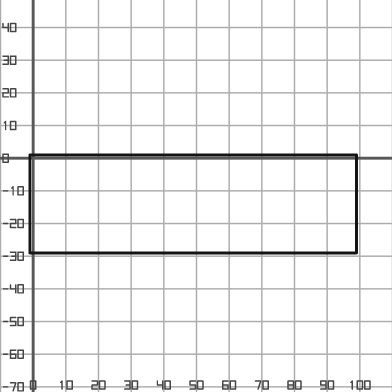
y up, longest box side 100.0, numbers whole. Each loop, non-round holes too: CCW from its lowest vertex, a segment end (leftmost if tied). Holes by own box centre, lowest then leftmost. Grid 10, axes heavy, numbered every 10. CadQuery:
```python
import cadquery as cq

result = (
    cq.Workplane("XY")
    .moveTo(-1.0, -29.0)
    .lineTo(99.0, -29.0)
    .lineTo(99.0, 1.0)
    .lineTo(-1.0, 1.0)
    .close()
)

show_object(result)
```